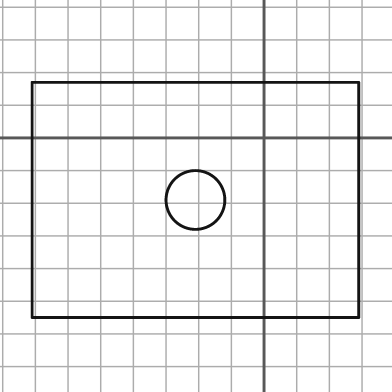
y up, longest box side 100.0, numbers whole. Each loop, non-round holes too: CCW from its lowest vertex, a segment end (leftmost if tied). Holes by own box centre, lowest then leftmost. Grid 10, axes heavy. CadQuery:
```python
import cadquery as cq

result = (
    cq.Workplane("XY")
    .moveTo(-71.0, -55.0)
    .lineTo(29.0, -55.0)
    .lineTo(29.0, 17.0)
    .lineTo(-71.0, 17.0)
    .close()
    .moveTo(-21.0, -19.0)
    .circle(9.0)
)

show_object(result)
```